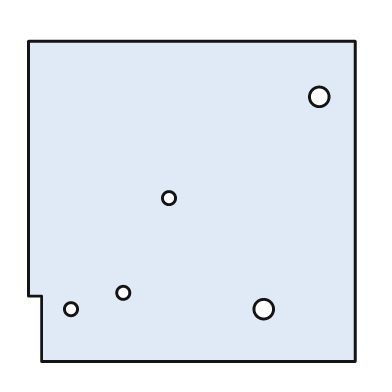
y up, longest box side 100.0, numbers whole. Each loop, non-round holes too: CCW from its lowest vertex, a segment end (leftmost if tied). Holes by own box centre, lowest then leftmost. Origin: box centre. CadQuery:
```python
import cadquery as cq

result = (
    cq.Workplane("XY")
    .moveTo(-46.0, -49.0)
    .lineTo(50.0, -49.0)
    .lineTo(50.0, 49.0)
    .lineTo(-50.0, 49.0)
    .lineTo(-50.0, -29.0)
    .lineTo(-46.0, -29.0)
    .close()
    .moveTo(-37.0, -33.0)
    .circle(2.0)
    .moveTo(22.0, -33.0)
    .circle(3.0)
    .moveTo(-21.0, -28.0)
    .circle(2.0)
    .moveTo(-7.0, 1.0)
    .circle(2.0)
    .moveTo(39.0, 32.0)
    .circle(3.0)
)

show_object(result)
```